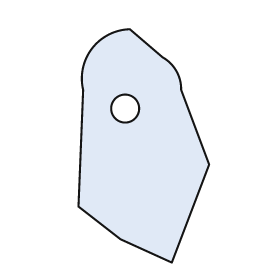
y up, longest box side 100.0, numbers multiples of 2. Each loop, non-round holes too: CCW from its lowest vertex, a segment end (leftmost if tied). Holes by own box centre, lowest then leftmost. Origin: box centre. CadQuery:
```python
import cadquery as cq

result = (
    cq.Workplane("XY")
    .moveTo(12.0, -50.0)
    .lineTo(28.0, -8.0)
    .lineTo(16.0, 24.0)
    .threePointArc((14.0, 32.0), (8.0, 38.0))
    .lineTo(-6.0, 50.0)
    .threePointArc((-22.0, 42.0), (-26.0, 24.0))
    .lineTo(-28.0, -26.0)
    .lineTo(-10.0, -40.0)
    .close()
    .moveTo(-8.0, 16.0)
    .circle(6.0)
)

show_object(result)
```